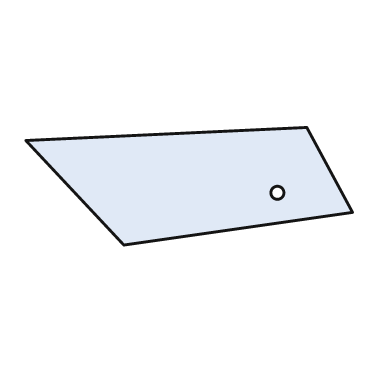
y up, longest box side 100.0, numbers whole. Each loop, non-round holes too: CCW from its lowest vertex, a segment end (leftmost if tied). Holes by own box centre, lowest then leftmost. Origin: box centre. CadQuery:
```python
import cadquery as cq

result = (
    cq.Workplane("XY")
    .moveTo(-20.0, -18.0)
    .lineTo(50.0, -8.0)
    .lineTo(36.0, 18.0)
    .lineTo(-50.0, 14.0)
    .close()
    .moveTo(27.0, -2.0)
    .circle(2.0)
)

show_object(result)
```